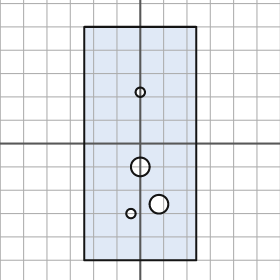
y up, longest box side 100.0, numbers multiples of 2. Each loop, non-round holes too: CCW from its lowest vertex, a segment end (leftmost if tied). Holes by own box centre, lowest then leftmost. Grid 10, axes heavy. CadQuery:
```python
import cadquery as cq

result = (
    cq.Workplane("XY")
    .moveTo(-24.0, -50.0)
    .lineTo(24.0, -50.0)
    .lineTo(24.0, 50.0)
    .lineTo(-24.0, 50.0)
    .close()
    .moveTo(-4.0, -30.0)
    .circle(2.0)
    .moveTo(8.0, -26.0)
    .circle(4.0)
    .moveTo(0.0, -10.0)
    .circle(4.0)
    .moveTo(0.0, 22.0)
    .circle(2.0)
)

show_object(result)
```